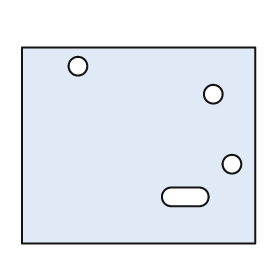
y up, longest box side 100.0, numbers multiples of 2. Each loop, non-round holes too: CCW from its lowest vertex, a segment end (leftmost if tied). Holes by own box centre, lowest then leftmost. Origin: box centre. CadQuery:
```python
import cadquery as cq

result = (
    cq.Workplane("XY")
    .moveTo(-50.0, -42.0)
    .lineTo(50.0, -42.0)
    .lineTo(50.0, 42.0)
    .lineTo(-50.0, 42.0)
    .close()
    .moveTo(14.0, -26.0)
    .lineTo(26.0, -26.0)
    .threePointArc((30.0, -22.0), (26.0, -18.0))
    .lineTo(14.0, -18.0)
    .threePointArc((10.0, -22.0), (14.0, -26.0))
    .close()
    .moveTo(40.0, -8.0)
    .circle(4.0)
    .moveTo(32.0, 22.0)
    .circle(4.0)
    .moveTo(-26.0, 34.0)
    .circle(4.0)
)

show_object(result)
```